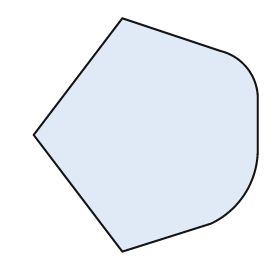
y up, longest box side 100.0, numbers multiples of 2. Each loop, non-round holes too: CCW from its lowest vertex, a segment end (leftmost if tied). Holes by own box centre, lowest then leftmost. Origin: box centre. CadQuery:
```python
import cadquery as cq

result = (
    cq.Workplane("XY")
    .moveTo(-10.0, -50.0)
    .lineTo(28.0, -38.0)
    .threePointArc((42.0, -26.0), (48.0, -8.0))
    .lineTo(48.0, 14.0)
    .threePointArc((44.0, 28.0), (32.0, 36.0))
    .lineTo(-10.0, 50.0)
    .lineTo(-48.0, 0.0)
    .close()
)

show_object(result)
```